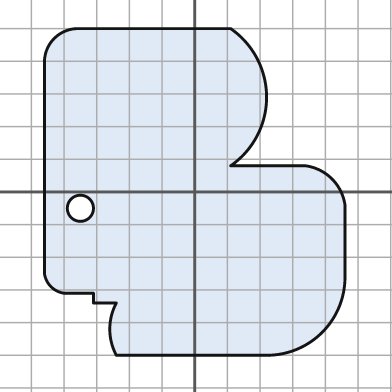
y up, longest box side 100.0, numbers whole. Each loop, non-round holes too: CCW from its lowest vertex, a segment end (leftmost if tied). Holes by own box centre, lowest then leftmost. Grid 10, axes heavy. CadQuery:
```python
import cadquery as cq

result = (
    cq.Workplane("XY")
    .moveTo(-24.0, -50.0)
    .lineTo(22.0, -50.0)
    .threePointArc((39.0, -43.0), (46.0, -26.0))
    .lineTo(46.0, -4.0)
    .threePointArc((42.0, 4.0), (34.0, 8.0))
    .lineTo(11.0, 8.0)
    .threePointArc((22.0, 29.0), (11.0, 50.0))
    .lineTo(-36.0, 50.0)
    .threePointArc((-43.0, 47.0), (-46.0, 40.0))
    .lineTo(-46.0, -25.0)
    .threePointArc((-44.0, -29.0), (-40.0, -31.0))
    .lineTo(-31.0, -31.0)
    .lineTo(-31.0, -34.0)
    .lineTo(-24.0, -34.0)
    .threePointArc((-26.0, -42.0), (-24.0, -50.0))
    .close()
    .moveTo(-35.0, -5.0)
    .circle(4.0)
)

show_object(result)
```